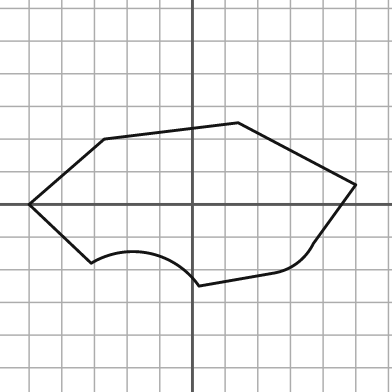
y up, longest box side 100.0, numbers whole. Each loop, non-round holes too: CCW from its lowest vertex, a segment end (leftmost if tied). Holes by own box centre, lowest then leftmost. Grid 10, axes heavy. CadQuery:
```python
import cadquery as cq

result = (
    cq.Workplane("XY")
    .moveTo(2.0, -25.0)
    .lineTo(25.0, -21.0)
    .threePointArc((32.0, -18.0), (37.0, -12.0))
    .lineTo(50.0, 6.0)
    .lineTo(14.0, 25.0)
    .lineTo(-27.0, 20.0)
    .lineTo(-50.0, 0.0)
    .lineTo(-31.0, -18.0)
    .threePointArc((-13.0, -15.0), (2.0, -25.0))
    .close()
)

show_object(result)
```